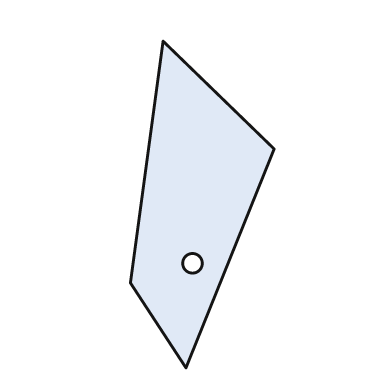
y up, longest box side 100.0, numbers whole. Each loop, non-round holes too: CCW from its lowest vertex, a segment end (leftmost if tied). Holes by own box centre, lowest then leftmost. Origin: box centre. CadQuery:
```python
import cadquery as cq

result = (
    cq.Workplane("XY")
    .moveTo(-5.0, -50.0)
    .lineTo(22.0, 17.0)
    .lineTo(-12.0, 50.0)
    .lineTo(-22.0, -24.0)
    .close()
    .moveTo(-3.0, -18.0)
    .circle(3.0)
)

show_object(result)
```